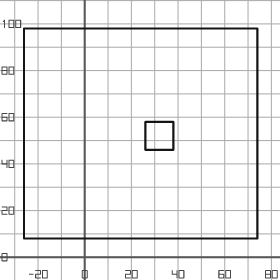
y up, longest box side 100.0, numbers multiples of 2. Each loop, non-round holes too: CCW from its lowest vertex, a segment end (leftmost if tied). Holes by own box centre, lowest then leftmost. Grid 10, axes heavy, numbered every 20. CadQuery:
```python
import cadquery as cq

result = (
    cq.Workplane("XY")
    .moveTo(-26.0, 8.0)
    .lineTo(74.0, 8.0)
    .lineTo(74.0, 98.0)
    .lineTo(-26.0, 98.0)
    .close()
    .moveTo(26.0, 46.0)
    .lineTo(38.0, 46.0)
    .lineTo(38.0, 58.0)
    .lineTo(26.0, 58.0)
    .close()
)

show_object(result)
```